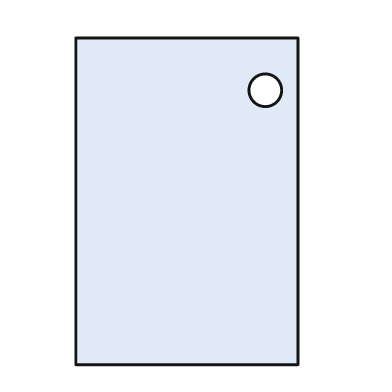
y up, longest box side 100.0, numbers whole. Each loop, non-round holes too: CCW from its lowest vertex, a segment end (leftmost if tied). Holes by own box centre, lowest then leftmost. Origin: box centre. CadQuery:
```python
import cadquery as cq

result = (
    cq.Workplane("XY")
    .moveTo(-34.0, -50.0)
    .lineTo(34.0, -50.0)
    .lineTo(34.0, 50.0)
    .lineTo(-34.0, 50.0)
    .close()
    .moveTo(24.0, 34.0)
    .circle(5.0)
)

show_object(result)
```